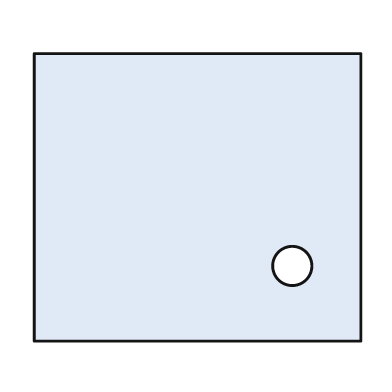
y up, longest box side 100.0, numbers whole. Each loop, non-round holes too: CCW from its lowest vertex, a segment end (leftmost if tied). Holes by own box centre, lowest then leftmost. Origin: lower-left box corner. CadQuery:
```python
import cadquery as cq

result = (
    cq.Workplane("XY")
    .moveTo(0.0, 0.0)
    .lineTo(100.0, 0.0)
    .lineTo(100.0, 88.0)
    .lineTo(0.0, 88.0)
    .close()
    .moveTo(79.0, 23.0)
    .circle(6.0)
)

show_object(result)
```